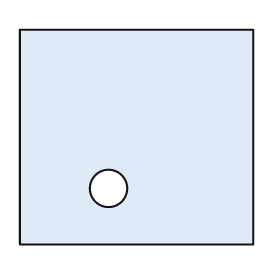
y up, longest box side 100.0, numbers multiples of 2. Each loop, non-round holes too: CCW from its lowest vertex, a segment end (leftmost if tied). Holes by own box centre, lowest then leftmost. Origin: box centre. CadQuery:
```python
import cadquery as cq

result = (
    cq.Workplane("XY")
    .moveTo(-50.0, -46.0)
    .lineTo(50.0, -46.0)
    .lineTo(50.0, 46.0)
    .lineTo(-50.0, 46.0)
    .close()
    .moveTo(-12.0, -22.0)
    .circle(8.0)
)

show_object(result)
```